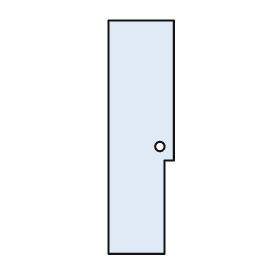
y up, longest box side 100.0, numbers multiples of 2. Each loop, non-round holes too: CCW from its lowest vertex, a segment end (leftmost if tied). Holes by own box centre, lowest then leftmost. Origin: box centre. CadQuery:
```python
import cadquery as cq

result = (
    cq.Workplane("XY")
    .moveTo(-14.0, -50.0)
    .lineTo(10.0, -50.0)
    .lineTo(10.0, -10.0)
    .lineTo(14.0, -10.0)
    .lineTo(14.0, 50.0)
    .lineTo(-14.0, 50.0)
    .close()
    .moveTo(8.0, -4.0)
    .circle(2.0)
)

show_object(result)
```